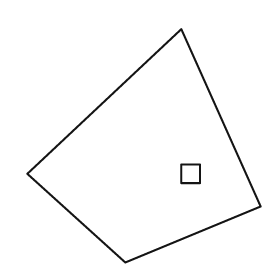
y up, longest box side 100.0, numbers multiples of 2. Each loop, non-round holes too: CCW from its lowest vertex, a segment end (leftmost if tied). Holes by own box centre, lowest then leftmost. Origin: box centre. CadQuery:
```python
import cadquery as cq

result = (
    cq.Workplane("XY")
    .moveTo(-8.0, -50.0)
    .lineTo(50.0, -26.0)
    .lineTo(16.0, 50.0)
    .lineTo(-50.0, -12.0)
    .close()
    .moveTo(16.0, -16.0)
    .lineTo(24.0, -16.0)
    .lineTo(24.0, -8.0)
    .lineTo(16.0, -8.0)
    .close()
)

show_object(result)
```